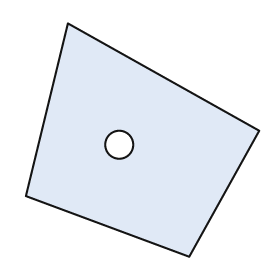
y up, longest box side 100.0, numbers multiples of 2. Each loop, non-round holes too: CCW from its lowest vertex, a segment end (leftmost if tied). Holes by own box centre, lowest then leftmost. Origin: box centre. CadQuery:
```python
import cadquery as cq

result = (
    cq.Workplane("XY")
    .moveTo(20.0, -50.0)
    .lineTo(50.0, 4.0)
    .lineTo(-32.0, 50.0)
    .lineTo(-50.0, -24.0)
    .close()
    .moveTo(-10.0, -2.0)
    .circle(6.0)
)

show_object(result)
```